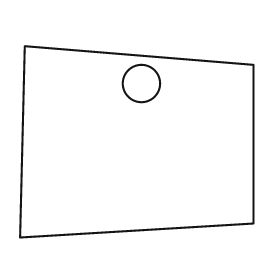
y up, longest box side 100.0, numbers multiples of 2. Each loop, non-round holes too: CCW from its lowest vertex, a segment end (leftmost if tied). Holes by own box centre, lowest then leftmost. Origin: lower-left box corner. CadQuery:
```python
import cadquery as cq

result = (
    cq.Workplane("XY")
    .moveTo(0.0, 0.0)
    .lineTo(100.0, 6.0)
    .lineTo(100.0, 74.0)
    .lineTo(2.0, 82.0)
    .close()
    .moveTo(52.0, 66.0)
    .circle(8.0)
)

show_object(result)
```